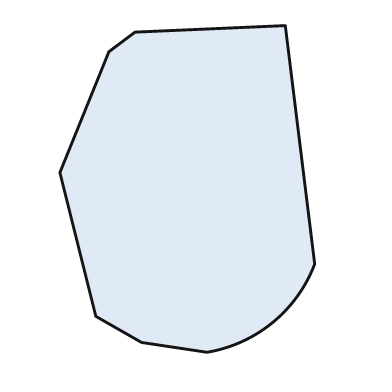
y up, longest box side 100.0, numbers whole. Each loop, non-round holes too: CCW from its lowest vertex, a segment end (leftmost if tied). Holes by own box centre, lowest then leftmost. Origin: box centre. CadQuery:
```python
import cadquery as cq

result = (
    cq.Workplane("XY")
    .moveTo(6.0, -50.0)
    .threePointArc((26.0, -41.0), (39.0, -23.0))
    .lineTo(30.0, 50.0)
    .lineTo(-16.0, 48.0)
    .lineTo(-24.0, 42.0)
    .lineTo(-39.0, 5.0)
    .lineTo(-28.0, -39.0)
    .lineTo(-14.0, -47.0)
    .close()
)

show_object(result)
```